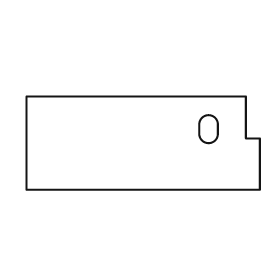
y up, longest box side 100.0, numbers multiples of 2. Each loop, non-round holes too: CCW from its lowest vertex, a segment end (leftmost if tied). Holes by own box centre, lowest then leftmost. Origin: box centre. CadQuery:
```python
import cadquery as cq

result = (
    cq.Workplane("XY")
    .moveTo(-50.0, -20.0)
    .lineTo(50.0, -20.0)
    .lineTo(50.0, 2.0)
    .lineTo(44.0, 2.0)
    .lineTo(44.0, 20.0)
    .lineTo(-50.0, 20.0)
    .close()
    .moveTo(24.0, 4.0)
    .threePointArc((28.0, 0.0), (32.0, 4.0))
    .lineTo(32.0, 8.0)
    .threePointArc((28.0, 12.0), (24.0, 8.0))
    .close()
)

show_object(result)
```